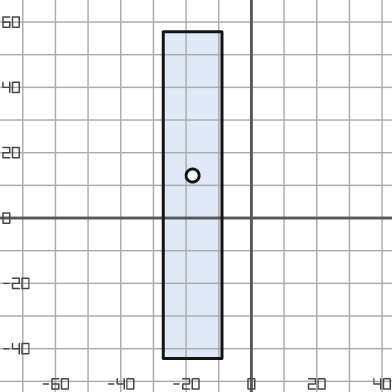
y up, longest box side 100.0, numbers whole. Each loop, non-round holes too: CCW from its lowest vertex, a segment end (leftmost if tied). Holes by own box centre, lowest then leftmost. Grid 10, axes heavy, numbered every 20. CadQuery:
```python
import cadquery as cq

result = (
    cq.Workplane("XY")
    .moveTo(-27.0, -43.0)
    .lineTo(-9.0, -43.0)
    .lineTo(-9.0, 57.0)
    .lineTo(-27.0, 57.0)
    .close()
    .moveTo(-18.0, 13.0)
    .circle(2.0)
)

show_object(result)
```